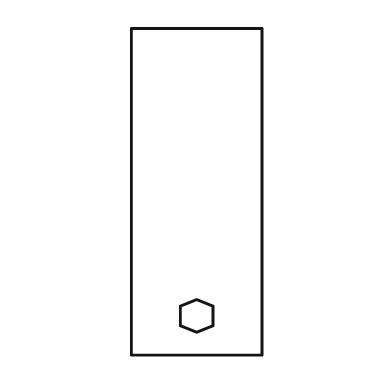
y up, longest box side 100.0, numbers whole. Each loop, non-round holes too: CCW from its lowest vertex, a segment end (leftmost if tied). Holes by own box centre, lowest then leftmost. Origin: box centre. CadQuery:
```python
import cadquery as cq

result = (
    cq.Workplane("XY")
    .moveTo(-20.0, -50.0)
    .lineTo(20.0, -50.0)
    .lineTo(20.0, 50.0)
    .lineTo(-20.0, 50.0)
    .close()
    .moveTo(0.0, -43.0)
    .lineTo(5.0, -41.0)
    .lineTo(5.0, -35.0)
    .lineTo(0.0, -33.0)
    .lineTo(-5.0, -35.0)
    .lineTo(-5.0, -41.0)
    .close()
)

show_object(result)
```